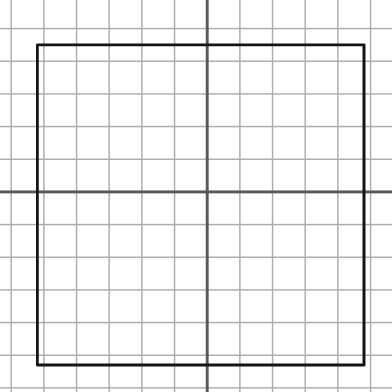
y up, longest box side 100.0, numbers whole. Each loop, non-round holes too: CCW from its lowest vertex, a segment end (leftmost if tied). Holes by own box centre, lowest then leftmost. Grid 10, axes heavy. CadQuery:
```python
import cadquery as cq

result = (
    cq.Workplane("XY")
    .moveTo(-52.0, -53.0)
    .lineTo(48.0, -53.0)
    .lineTo(48.0, 45.0)
    .lineTo(-52.0, 45.0)
    .close()
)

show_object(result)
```